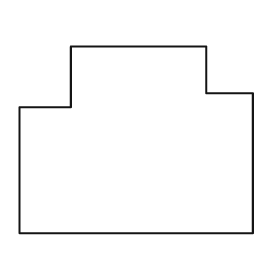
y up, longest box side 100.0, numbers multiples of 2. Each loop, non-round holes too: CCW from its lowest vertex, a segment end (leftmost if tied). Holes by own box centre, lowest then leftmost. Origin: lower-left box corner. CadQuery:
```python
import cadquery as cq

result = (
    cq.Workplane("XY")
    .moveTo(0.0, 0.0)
    .lineTo(100.0, 0.0)
    .lineTo(100.0, 60.0)
    .lineTo(80.0, 60.0)
    .lineTo(80.0, 80.0)
    .lineTo(22.0, 80.0)
    .lineTo(22.0, 54.0)
    .lineTo(0.0, 54.0)
    .close()
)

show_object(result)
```